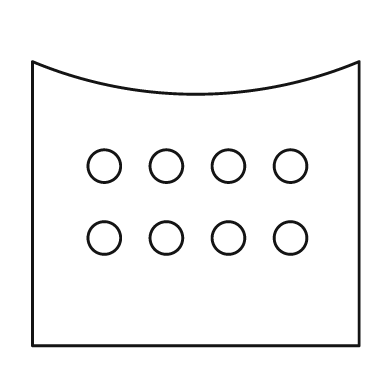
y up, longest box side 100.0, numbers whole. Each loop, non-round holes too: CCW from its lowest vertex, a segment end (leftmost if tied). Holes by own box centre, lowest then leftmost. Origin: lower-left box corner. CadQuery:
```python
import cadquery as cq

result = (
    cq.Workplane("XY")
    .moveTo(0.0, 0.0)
    .lineTo(100.0, 0.0)
    .lineTo(100.0, 87.0)
    .threePointArc((50.0, 77.0), (0.0, 87.0))
    .close()
    .moveTo(22.0, 33.0)
    .circle(5.0)
    .moveTo(41.0, 33.0)
    .circle(5.0)
    .moveTo(60.0, 33.0)
    .circle(5.0)
    .moveTo(79.0, 33.0)
    .circle(5.0)
    .moveTo(22.0, 55.0)
    .circle(5.0)
    .moveTo(41.0, 55.0)
    .circle(5.0)
    .moveTo(60.0, 55.0)
    .circle(5.0)
    .moveTo(79.0, 55.0)
    .circle(5.0)
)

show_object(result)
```